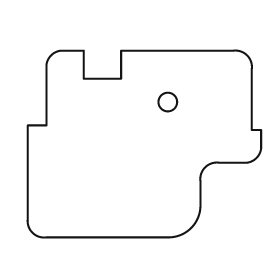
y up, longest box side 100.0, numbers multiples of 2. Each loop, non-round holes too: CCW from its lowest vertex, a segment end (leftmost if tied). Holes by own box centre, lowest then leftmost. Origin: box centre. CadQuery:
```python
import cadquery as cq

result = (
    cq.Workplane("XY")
    .moveTo(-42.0, -40.0)
    .lineTo(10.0, -40.0)
    .threePointArc((20.0, -36.0), (24.0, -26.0))
    .lineTo(24.0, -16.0)
    .threePointArc((26.0, -10.0), (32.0, -8.0))
    .lineTo(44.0, -8.0)
    .threePointArc((48.0, -6.0), (50.0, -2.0))
    .lineTo(50.0, 6.0)
    .lineTo(46.0, 6.0)
    .lineTo(46.0, 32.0)
    .threePointArc((44.0, 38.0), (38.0, 40.0))
    .lineTo(-10.0, 40.0)
    .lineTo(-10.0, 28.0)
    .lineTo(-26.0, 28.0)
    .lineTo(-26.0, 40.0)
    .lineTo(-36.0, 40.0)
    .threePointArc((-40.0, 38.0), (-42.0, 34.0))
    .lineTo(-42.0, 8.0)
    .lineTo(-50.0, 8.0)
    .lineTo(-50.0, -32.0)
    .threePointArc((-48.0, -38.0), (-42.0, -40.0))
    .close()
    .moveTo(10.0, 18.0)
    .circle(4.0)
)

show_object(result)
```